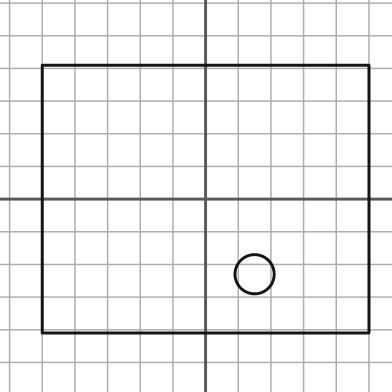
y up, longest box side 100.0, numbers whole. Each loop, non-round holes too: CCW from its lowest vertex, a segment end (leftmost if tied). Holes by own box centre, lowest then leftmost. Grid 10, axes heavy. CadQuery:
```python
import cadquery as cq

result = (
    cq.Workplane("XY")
    .moveTo(-50.0, -41.0)
    .lineTo(50.0, -41.0)
    .lineTo(50.0, 41.0)
    .lineTo(-50.0, 41.0)
    .close()
    .moveTo(15.0, -23.0)
    .circle(6.0)
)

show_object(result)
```